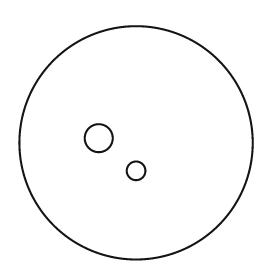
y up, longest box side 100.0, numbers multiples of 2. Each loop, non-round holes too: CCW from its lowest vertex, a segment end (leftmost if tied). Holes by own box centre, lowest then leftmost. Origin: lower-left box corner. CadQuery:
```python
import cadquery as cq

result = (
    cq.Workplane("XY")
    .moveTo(50.0, 50.0)
    .circle(50.0)
    .moveTo(50.0, 38.0)
    .circle(4.0)
    .moveTo(34.0, 52.0)
    .circle(6.0)
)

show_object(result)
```